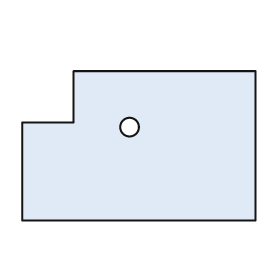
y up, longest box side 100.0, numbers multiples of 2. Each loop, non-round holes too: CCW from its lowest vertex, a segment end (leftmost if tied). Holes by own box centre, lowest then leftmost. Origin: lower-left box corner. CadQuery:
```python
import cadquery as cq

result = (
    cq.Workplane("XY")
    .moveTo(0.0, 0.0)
    .lineTo(100.0, 0.0)
    .lineTo(100.0, 64.0)
    .lineTo(22.0, 64.0)
    .lineTo(22.0, 42.0)
    .lineTo(0.0, 42.0)
    .close()
    .moveTo(46.0, 40.0)
    .circle(4.0)
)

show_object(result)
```